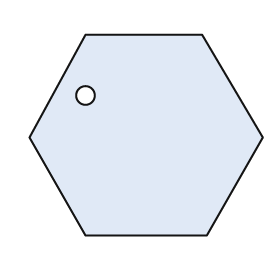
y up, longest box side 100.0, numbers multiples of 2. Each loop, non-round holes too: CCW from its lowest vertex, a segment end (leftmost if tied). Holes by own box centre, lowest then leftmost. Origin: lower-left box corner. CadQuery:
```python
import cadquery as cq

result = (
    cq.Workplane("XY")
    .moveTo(24.0, 0.0)
    .lineTo(76.0, 0.0)
    .lineTo(100.0, 42.0)
    .lineTo(74.0, 86.0)
    .lineTo(24.0, 86.0)
    .lineTo(0.0, 42.0)
    .close()
    .moveTo(24.0, 60.0)
    .circle(4.0)
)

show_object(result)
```